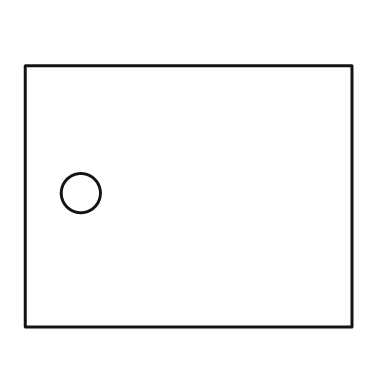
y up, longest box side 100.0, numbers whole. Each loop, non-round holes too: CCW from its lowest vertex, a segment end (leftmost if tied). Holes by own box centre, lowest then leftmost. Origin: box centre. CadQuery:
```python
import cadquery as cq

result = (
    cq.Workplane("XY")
    .moveTo(-50.0, -40.0)
    .lineTo(50.0, -40.0)
    .lineTo(50.0, 40.0)
    .lineTo(-50.0, 40.0)
    .close()
    .moveTo(-33.0, 1.0)
    .circle(6.0)
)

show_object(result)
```